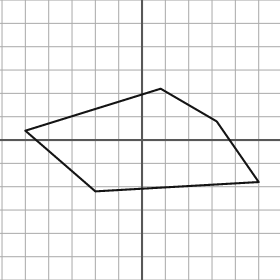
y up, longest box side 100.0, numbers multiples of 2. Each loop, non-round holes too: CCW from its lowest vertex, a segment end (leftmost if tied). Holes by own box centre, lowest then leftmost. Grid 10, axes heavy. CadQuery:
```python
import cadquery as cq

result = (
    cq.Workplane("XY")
    .moveTo(-20.0, -22.0)
    .lineTo(50.0, -18.0)
    .lineTo(32.0, 8.0)
    .lineTo(8.0, 22.0)
    .lineTo(-50.0, 4.0)
    .close()
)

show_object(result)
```